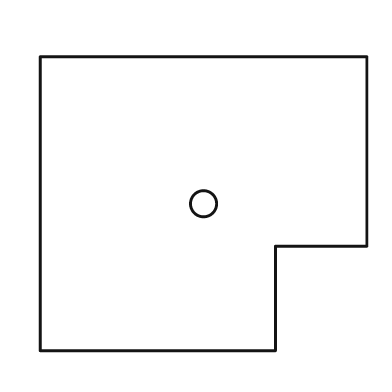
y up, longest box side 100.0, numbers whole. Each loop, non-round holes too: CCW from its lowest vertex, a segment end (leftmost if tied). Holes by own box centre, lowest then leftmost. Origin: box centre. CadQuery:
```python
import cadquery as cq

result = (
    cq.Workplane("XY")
    .moveTo(-50.0, -45.0)
    .lineTo(22.0, -45.0)
    .lineTo(22.0, -13.0)
    .lineTo(50.0, -13.0)
    .lineTo(50.0, 45.0)
    .lineTo(-50.0, 45.0)
    .close()
    .moveTo(0.0, 0.0)
    .circle(4.0)
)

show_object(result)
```